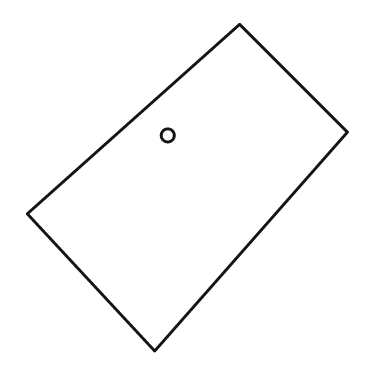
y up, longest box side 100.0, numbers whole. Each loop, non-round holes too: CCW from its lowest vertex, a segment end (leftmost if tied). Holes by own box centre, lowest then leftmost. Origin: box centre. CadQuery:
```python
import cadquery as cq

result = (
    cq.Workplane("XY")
    .moveTo(-10.0, -50.0)
    .lineTo(49.0, 17.0)
    .lineTo(16.0, 50.0)
    .lineTo(-49.0, -8.0)
    .close()
    .moveTo(-6.0, 16.0)
    .circle(2.0)
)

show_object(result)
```